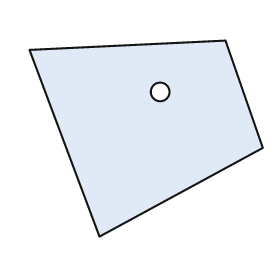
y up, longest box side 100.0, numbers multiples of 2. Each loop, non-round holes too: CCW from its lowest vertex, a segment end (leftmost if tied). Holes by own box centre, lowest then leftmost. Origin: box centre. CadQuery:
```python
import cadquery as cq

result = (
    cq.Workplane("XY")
    .moveTo(-20.0, -42.0)
    .lineTo(50.0, -4.0)
    .lineTo(34.0, 42.0)
    .lineTo(-50.0, 38.0)
    .close()
    .moveTo(6.0, 20.0)
    .circle(4.0)
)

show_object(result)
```